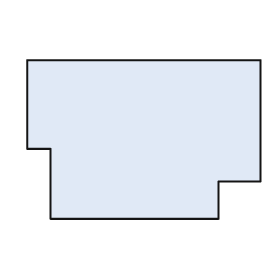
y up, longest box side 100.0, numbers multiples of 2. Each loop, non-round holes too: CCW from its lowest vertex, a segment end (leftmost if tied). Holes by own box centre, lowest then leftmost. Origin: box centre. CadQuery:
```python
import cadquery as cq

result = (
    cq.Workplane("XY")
    .moveTo(-40.0, -34.0)
    .lineTo(32.0, -34.0)
    .lineTo(32.0, -18.0)
    .lineTo(50.0, -18.0)
    .lineTo(50.0, 34.0)
    .lineTo(-50.0, 34.0)
    .lineTo(-50.0, -4.0)
    .lineTo(-40.0, -4.0)
    .close()
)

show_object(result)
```